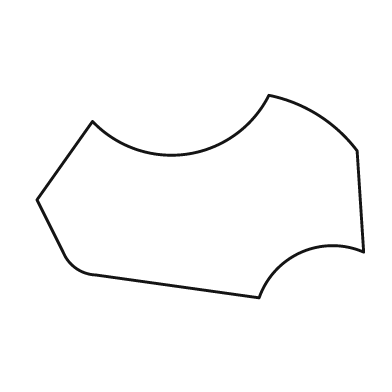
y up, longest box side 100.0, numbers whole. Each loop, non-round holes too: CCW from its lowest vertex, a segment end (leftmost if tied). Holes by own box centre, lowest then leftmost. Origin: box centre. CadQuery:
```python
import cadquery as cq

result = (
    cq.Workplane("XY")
    .moveTo(18.0, -31.0)
    .threePointArc((31.0, -17.0), (50.0, -17.0))
    .lineTo(48.0, 14.0)
    .threePointArc((36.0, 25.0), (21.0, 31.0))
    .threePointArc((-4.0, 13.0), (-33.0, 23.0))
    .lineTo(-50.0, -1.0)
    .lineTo(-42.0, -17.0)
    .threePointArc((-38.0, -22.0), (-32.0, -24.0))
    .close()
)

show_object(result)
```